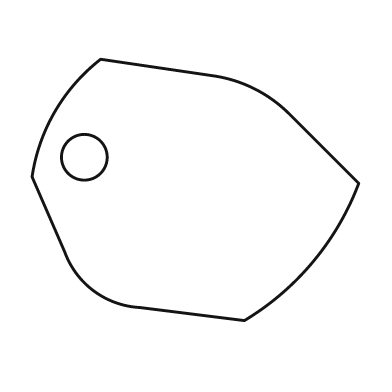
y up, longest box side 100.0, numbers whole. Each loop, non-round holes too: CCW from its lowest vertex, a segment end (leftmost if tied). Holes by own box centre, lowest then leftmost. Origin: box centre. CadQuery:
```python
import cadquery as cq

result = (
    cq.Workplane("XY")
    .moveTo(15.0, -40.0)
    .threePointArc((36.0, -22.0), (50.0, 2.0))
    .lineTo(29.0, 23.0)
    .threePointArc((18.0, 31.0), (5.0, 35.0))
    .lineTo(-29.0, 40.0)
    .threePointArc((-43.0, 24.0), (-50.0, 4.0))
    .lineTo(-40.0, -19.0)
    .threePointArc((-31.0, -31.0), (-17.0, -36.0))
    .close()
    .moveTo(-34.0, 10.0)
    .circle(7.0)
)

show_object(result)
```